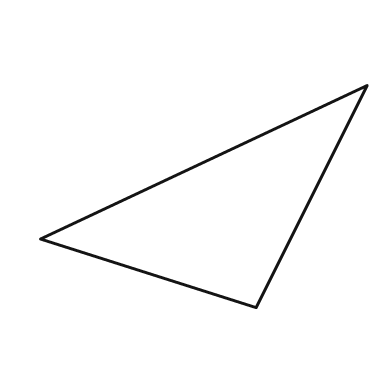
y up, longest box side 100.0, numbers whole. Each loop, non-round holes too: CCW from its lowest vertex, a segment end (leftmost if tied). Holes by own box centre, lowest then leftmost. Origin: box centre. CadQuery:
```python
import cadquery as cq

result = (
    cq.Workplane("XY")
    .moveTo(16.0, -34.0)
    .lineTo(50.0, 34.0)
    .lineTo(-50.0, -13.0)
    .close()
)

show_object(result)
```